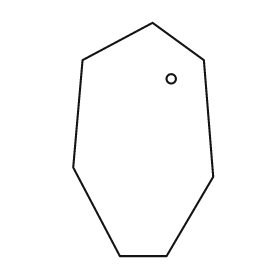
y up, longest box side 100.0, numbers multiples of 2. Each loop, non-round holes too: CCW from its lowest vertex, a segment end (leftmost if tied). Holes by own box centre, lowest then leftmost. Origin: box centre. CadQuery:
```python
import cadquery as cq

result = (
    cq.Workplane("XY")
    .moveTo(-10.0, -50.0)
    .lineTo(10.0, -50.0)
    .lineTo(30.0, -16.0)
    .lineTo(26.0, 34.0)
    .lineTo(4.0, 50.0)
    .lineTo(-26.0, 34.0)
    .lineTo(-30.0, -12.0)
    .close()
    .moveTo(12.0, 26.0)
    .circle(2.0)
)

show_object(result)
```